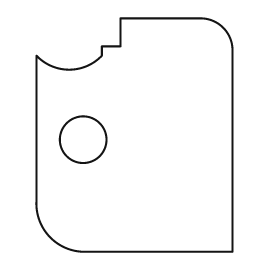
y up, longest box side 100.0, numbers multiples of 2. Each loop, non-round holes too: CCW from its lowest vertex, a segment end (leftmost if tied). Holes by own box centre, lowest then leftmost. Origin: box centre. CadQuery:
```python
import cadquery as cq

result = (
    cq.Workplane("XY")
    .moveTo(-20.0, -50.0)
    .lineTo(42.0, -50.0)
    .lineTo(42.0, 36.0)
    .threePointArc((38.0, 46.0), (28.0, 50.0))
    .lineTo(-6.0, 50.0)
    .lineTo(-6.0, 38.0)
    .lineTo(-14.0, 38.0)
    .lineTo(-14.0, 34.0)
    .threePointArc((-28.0, 28.0), (-42.0, 34.0))
    .lineTo(-42.0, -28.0)
    .threePointArc((-36.0, -44.0), (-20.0, -50.0))
    .close()
    .moveTo(-22.0, -2.0)
    .circle(10.0)
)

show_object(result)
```